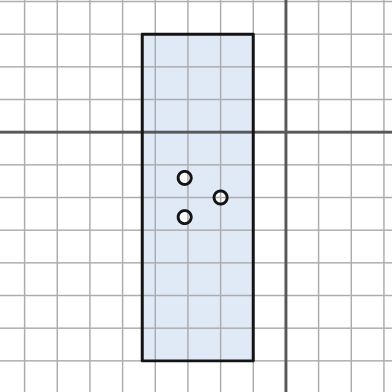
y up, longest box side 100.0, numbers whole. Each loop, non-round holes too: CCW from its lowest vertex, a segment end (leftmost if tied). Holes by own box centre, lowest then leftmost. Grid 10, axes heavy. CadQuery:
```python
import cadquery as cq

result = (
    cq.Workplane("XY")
    .moveTo(-44.0, -70.0)
    .lineTo(-10.0, -70.0)
    .lineTo(-10.0, 30.0)
    .lineTo(-44.0, 30.0)
    .close()
    .moveTo(-31.0, -26.0)
    .circle(2.0)
    .moveTo(-20.0, -20.0)
    .circle(2.0)
    .moveTo(-31.0, -14.0)
    .circle(2.0)
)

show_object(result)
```